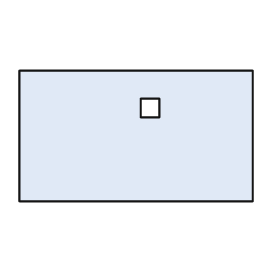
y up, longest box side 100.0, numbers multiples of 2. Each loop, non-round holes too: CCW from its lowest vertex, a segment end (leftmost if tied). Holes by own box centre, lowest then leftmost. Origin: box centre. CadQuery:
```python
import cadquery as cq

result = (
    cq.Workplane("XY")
    .moveTo(-50.0, -28.0)
    .lineTo(50.0, -28.0)
    .lineTo(50.0, 28.0)
    .lineTo(-50.0, 28.0)
    .close()
    .moveTo(2.0, 8.0)
    .lineTo(10.0, 8.0)
    .lineTo(10.0, 16.0)
    .lineTo(2.0, 16.0)
    .close()
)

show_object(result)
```